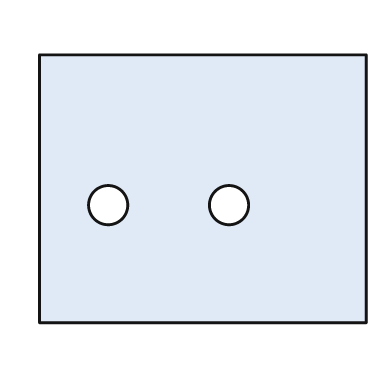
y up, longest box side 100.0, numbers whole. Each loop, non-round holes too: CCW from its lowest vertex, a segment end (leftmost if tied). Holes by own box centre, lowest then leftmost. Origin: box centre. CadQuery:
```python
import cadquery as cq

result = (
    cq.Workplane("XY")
    .moveTo(-50.0, -41.0)
    .lineTo(50.0, -41.0)
    .lineTo(50.0, 41.0)
    .lineTo(-50.0, 41.0)
    .close()
    .moveTo(-29.0, -5.0)
    .circle(6.0)
    .moveTo(8.0, -5.0)
    .circle(6.0)
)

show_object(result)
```